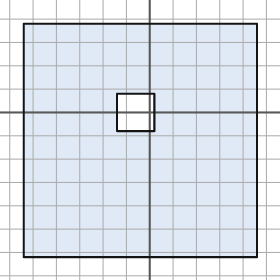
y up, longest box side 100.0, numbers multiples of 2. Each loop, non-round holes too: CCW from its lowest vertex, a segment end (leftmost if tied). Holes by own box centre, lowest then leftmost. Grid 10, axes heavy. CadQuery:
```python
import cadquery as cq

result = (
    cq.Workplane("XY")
    .moveTo(-54.0, -62.0)
    .lineTo(46.0, -62.0)
    .lineTo(46.0, 38.0)
    .lineTo(-54.0, 38.0)
    .close()
    .moveTo(-14.0, -8.0)
    .lineTo(2.0, -8.0)
    .lineTo(2.0, 8.0)
    .lineTo(-14.0, 8.0)
    .close()
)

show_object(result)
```